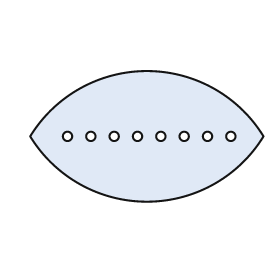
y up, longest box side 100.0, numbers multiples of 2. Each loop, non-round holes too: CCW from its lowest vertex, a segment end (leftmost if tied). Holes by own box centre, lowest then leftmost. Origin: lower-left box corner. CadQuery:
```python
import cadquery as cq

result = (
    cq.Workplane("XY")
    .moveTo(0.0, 28.0)
    .threePointArc((50.0, 0.0), (100.0, 28.0))
    .threePointArc((50.0, 56.0), (0.0, 28.0))
    .close()
    .moveTo(16.0, 28.0)
    .circle(2.0)
    .moveTo(26.0, 28.0)
    .circle(2.0)
    .moveTo(36.0, 28.0)
    .circle(2.0)
    .moveTo(46.0, 28.0)
    .circle(2.0)
    .moveTo(56.0, 28.0)
    .circle(2.0)
    .moveTo(66.0, 28.0)
    .circle(2.0)
    .moveTo(76.0, 28.0)
    .circle(2.0)
    .moveTo(86.0, 28.0)
    .circle(2.0)
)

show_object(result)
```